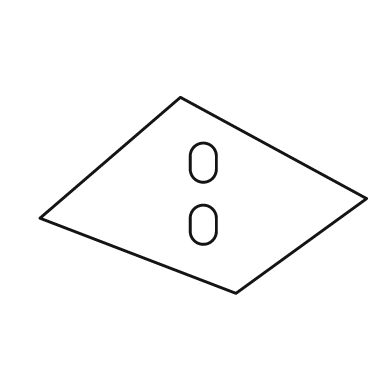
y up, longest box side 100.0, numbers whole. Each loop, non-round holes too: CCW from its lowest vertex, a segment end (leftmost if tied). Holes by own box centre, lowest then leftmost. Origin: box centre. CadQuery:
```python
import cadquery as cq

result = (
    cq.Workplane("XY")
    .moveTo(10.0, -30.0)
    .lineTo(50.0, -1.0)
    .lineTo(-7.0, 30.0)
    .lineTo(-50.0, -7.0)
    .close()
    .moveTo(-4.0, -11.0)
    .threePointArc((0.0, -15.0), (4.0, -11.0))
    .lineTo(4.0, -7.0)
    .threePointArc((0.0, -3.0), (-4.0, -7.0))
    .close()
    .moveTo(-4.0, 8.0)
    .threePointArc((0.0, 4.0), (4.0, 8.0))
    .lineTo(4.0, 12.0)
    .threePointArc((0.0, 16.0), (-4.0, 12.0))
    .close()
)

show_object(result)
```